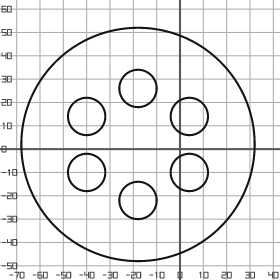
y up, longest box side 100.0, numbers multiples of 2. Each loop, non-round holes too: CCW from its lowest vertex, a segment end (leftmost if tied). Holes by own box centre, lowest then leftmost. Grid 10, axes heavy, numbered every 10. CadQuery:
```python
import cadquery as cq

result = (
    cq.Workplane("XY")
    .moveTo(-18.0, 2.0)
    .circle(50.0)
    .moveTo(-18.0, -22.0)
    .circle(8.0)
    .moveTo(-40.0, -10.0)
    .circle(8.0)
    .moveTo(4.0, -10.0)
    .circle(8.0)
    .moveTo(-40.0, 14.0)
    .circle(8.0)
    .moveTo(4.0, 14.0)
    .circle(8.0)
    .moveTo(-18.0, 26.0)
    .circle(8.0)
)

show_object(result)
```